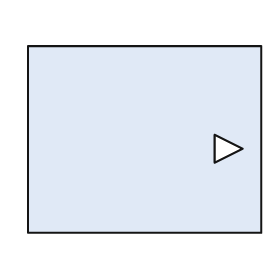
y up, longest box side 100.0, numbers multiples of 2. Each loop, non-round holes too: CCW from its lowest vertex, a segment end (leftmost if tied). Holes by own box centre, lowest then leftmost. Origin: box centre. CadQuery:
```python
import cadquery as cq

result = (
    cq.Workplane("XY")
    .moveTo(-50.0, -40.0)
    .lineTo(50.0, -40.0)
    .lineTo(50.0, 40.0)
    .lineTo(-50.0, 40.0)
    .close()
    .moveTo(30.0, -10.0)
    .lineTo(42.0, -4.0)
    .lineTo(30.0, 2.0)
    .close()
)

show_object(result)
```